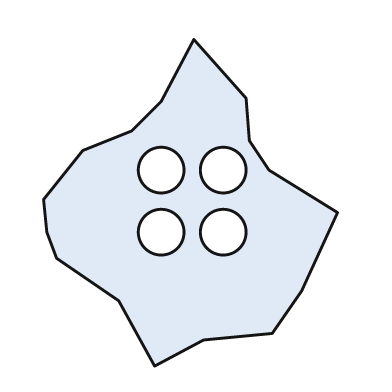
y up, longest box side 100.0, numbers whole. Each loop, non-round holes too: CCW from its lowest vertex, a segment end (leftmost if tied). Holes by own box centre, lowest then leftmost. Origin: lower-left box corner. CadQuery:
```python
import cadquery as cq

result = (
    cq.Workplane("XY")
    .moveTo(34.0, 0.0)
    .lineTo(49.0, 8.0)
    .lineTo(70.0, 10.0)
    .lineTo(79.0, 23.0)
    .lineTo(90.0, 47.0)
    .lineTo(69.0, 60.0)
    .lineTo(63.0, 69.0)
    .lineTo(62.0, 82.0)
    .lineTo(46.0, 100.0)
    .lineTo(36.0, 81.0)
    .lineTo(27.0, 72.0)
    .lineTo(12.0, 66.0)
    .lineTo(0.0, 51.0)
    .lineTo(1.0, 41.0)
    .lineTo(4.0, 33.0)
    .lineTo(23.0, 20.0)
    .close()
    .moveTo(36.0, 41.0)
    .circle(7.0)
    .moveTo(55.0, 41.0)
    .circle(7.0)
    .moveTo(36.0, 60.0)
    .circle(7.0)
    .moveTo(55.0, 60.0)
    .circle(7.0)
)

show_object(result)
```